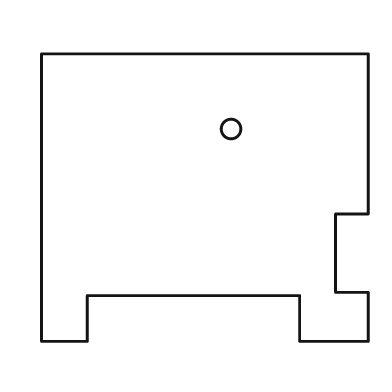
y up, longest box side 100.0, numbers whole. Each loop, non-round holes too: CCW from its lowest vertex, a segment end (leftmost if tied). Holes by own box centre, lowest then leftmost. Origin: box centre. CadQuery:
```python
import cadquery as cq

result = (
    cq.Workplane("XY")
    .moveTo(-50.0, -44.0)
    .lineTo(-36.0, -44.0)
    .lineTo(-36.0, -30.0)
    .lineTo(29.0, -30.0)
    .lineTo(29.0, -44.0)
    .lineTo(50.0, -44.0)
    .lineTo(50.0, -29.0)
    .lineTo(40.0, -29.0)
    .lineTo(40.0, -5.0)
    .lineTo(50.0, -5.0)
    .lineTo(50.0, 44.0)
    .lineTo(-50.0, 44.0)
    .close()
    .moveTo(8.0, 21.0)
    .circle(3.0)
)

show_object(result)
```